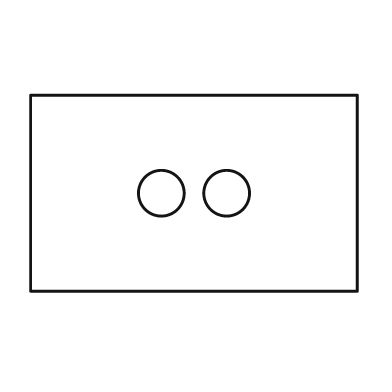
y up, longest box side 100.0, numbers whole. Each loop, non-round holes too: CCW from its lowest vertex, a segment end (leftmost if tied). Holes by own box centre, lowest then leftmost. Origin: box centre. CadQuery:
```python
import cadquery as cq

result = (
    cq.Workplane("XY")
    .moveTo(-50.0, -30.0)
    .lineTo(50.0, -30.0)
    .lineTo(50.0, 30.0)
    .lineTo(-50.0, 30.0)
    .close()
    .moveTo(-10.0, 0.0)
    .circle(7.0)
    .moveTo(10.0, 0.0)
    .circle(7.0)
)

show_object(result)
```